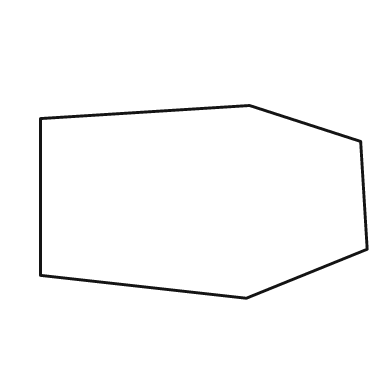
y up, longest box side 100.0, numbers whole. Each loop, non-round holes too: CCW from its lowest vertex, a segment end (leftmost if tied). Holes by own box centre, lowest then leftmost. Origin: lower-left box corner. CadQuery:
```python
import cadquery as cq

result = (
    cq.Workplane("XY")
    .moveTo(63.0, 0.0)
    .lineTo(100.0, 15.0)
    .lineTo(98.0, 48.0)
    .lineTo(64.0, 59.0)
    .lineTo(0.0, 55.0)
    .lineTo(0.0, 7.0)
    .close()
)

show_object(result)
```